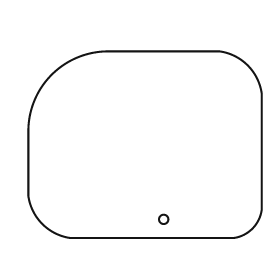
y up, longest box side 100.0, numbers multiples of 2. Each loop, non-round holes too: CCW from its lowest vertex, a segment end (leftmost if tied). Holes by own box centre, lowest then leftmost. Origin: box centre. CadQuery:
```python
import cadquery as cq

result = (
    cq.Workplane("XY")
    .moveTo(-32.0, -40.0)
    .lineTo(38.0, -40.0)
    .threePointArc((46.0, -36.0), (50.0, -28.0))
    .lineTo(50.0, 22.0)
    .threePointArc((44.0, 34.0), (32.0, 40.0))
    .lineTo(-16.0, 40.0)
    .threePointArc((-40.0, 30.0), (-50.0, 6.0))
    .lineTo(-50.0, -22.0)
    .threePointArc((-44.0, -34.0), (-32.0, -40.0))
    .close()
    .moveTo(8.0, -32.0)
    .circle(2.0)
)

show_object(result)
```